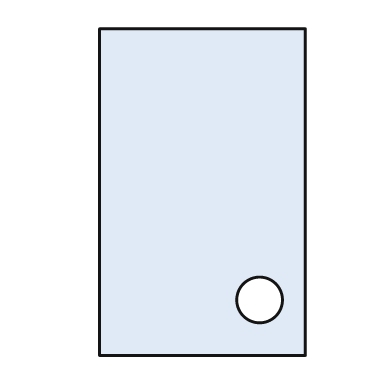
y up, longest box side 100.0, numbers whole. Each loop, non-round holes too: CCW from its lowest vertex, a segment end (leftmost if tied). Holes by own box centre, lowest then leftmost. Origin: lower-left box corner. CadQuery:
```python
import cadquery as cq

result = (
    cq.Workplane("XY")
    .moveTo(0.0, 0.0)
    .lineTo(63.0, 0.0)
    .lineTo(63.0, 100.0)
    .lineTo(0.0, 100.0)
    .close()
    .moveTo(49.0, 17.0)
    .circle(7.0)
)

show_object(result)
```